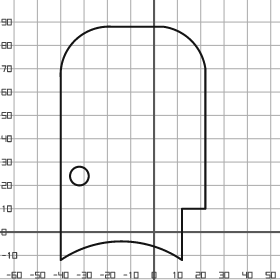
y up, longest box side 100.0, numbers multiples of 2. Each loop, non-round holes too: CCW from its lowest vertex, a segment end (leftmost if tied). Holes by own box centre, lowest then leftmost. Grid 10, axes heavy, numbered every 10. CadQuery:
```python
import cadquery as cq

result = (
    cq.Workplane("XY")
    .moveTo(-40.0, -12.0)
    .threePointArc((-14.0, -4.0), (12.0, -12.0))
    .lineTo(12.0, 10.0)
    .lineTo(22.0, 10.0)
    .lineTo(22.0, 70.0)
    .threePointArc((16.0, 82.0), (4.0, 88.0))
    .lineTo(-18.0, 88.0)
    .threePointArc((-34.0, 82.0), (-40.0, 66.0))
    .close()
    .moveTo(-32.0, 24.0)
    .circle(4.0)
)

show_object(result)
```